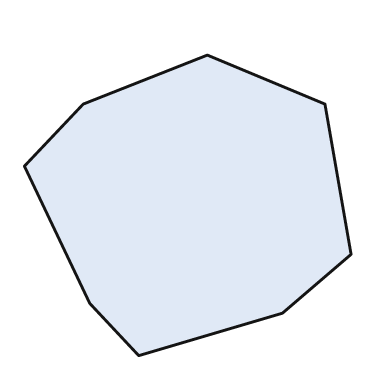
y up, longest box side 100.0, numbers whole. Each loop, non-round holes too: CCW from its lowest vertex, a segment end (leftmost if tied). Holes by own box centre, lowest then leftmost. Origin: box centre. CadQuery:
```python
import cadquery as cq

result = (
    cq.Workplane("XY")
    .moveTo(-15.0, -46.0)
    .lineTo(29.0, -33.0)
    .lineTo(50.0, -15.0)
    .lineTo(42.0, 31.0)
    .lineTo(6.0, 46.0)
    .lineTo(-32.0, 31.0)
    .lineTo(-50.0, 12.0)
    .lineTo(-30.0, -30.0)
    .close()
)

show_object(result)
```